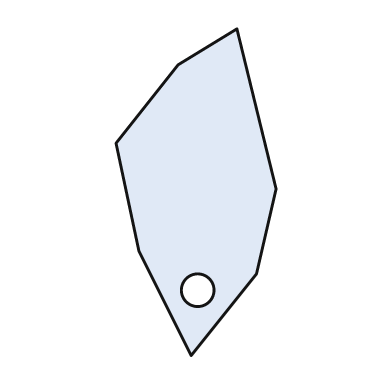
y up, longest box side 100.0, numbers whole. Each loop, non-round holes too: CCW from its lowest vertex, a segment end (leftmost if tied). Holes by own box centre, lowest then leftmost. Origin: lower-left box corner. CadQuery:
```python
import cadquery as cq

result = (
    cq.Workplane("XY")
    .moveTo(23.0, 0.0)
    .lineTo(43.0, 25.0)
    .lineTo(49.0, 51.0)
    .lineTo(37.0, 100.0)
    .lineTo(19.0, 89.0)
    .lineTo(0.0, 65.0)
    .lineTo(7.0, 32.0)
    .close()
    .moveTo(25.0, 20.0)
    .circle(5.0)
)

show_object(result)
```